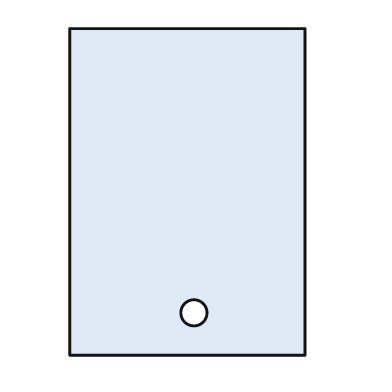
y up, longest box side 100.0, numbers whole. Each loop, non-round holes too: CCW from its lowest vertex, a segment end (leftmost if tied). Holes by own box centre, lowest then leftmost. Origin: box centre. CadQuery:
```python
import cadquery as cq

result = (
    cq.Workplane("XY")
    .moveTo(-36.0, -50.0)
    .lineTo(36.0, -50.0)
    .lineTo(36.0, 50.0)
    .lineTo(-36.0, 50.0)
    .close()
    .moveTo(2.0, -37.0)
    .circle(4.0)
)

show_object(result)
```